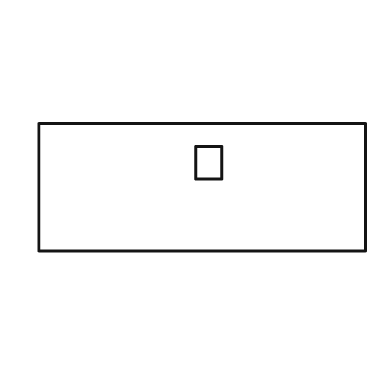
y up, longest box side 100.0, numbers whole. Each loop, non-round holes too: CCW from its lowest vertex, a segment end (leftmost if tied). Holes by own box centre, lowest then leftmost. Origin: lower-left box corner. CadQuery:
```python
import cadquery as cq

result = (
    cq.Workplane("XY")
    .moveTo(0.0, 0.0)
    .lineTo(100.0, 0.0)
    .lineTo(100.0, 39.0)
    .lineTo(0.0, 39.0)
    .close()
    .moveTo(48.0, 22.0)
    .lineTo(56.0, 22.0)
    .lineTo(56.0, 32.0)
    .lineTo(48.0, 32.0)
    .close()
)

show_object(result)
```